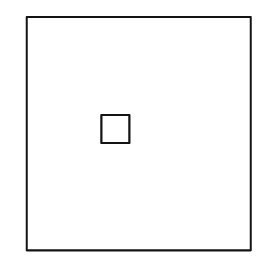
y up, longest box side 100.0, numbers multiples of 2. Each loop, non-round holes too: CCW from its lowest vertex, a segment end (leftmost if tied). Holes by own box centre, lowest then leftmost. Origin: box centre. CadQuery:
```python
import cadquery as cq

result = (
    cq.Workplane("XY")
    .moveTo(-48.0, -50.0)
    .lineTo(48.0, -50.0)
    .lineTo(48.0, 50.0)
    .lineTo(-48.0, 50.0)
    .close()
    .moveTo(-16.0, -4.0)
    .lineTo(-4.0, -4.0)
    .lineTo(-4.0, 8.0)
    .lineTo(-16.0, 8.0)
    .close()
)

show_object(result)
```